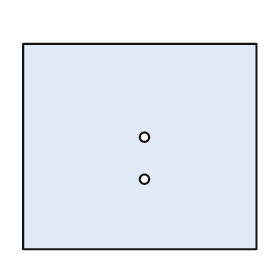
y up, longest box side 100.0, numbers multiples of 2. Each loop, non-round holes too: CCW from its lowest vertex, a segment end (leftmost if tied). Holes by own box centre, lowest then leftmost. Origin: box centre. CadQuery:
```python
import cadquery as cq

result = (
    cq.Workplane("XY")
    .moveTo(-50.0, -44.0)
    .lineTo(50.0, -44.0)
    .lineTo(50.0, 44.0)
    .lineTo(-50.0, 44.0)
    .close()
    .moveTo(2.0, -14.0)
    .circle(2.0)
    .moveTo(2.0, 4.0)
    .circle(2.0)
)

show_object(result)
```